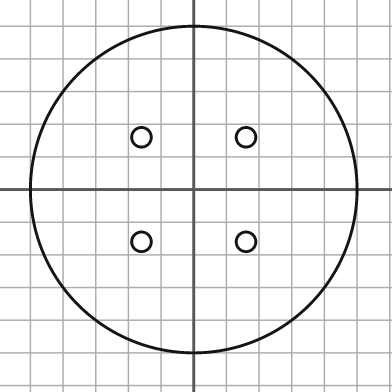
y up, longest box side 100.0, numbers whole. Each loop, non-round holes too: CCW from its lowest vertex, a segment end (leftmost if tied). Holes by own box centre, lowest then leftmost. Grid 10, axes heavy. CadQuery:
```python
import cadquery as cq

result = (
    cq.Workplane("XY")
    .moveTo(0.0, 0.0)
    .circle(50.0)
    .moveTo(-16.0, -16.0)
    .circle(3.0)
    .moveTo(16.0, -16.0)
    .circle(3.0)
    .moveTo(-16.0, 16.0)
    .circle(3.0)
    .moveTo(16.0, 16.0)
    .circle(3.0)
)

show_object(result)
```